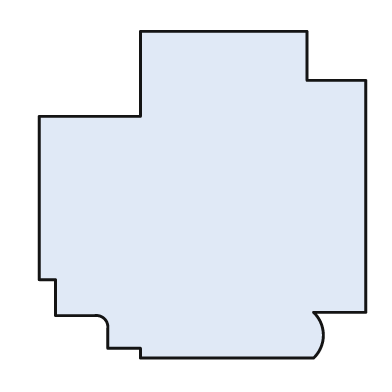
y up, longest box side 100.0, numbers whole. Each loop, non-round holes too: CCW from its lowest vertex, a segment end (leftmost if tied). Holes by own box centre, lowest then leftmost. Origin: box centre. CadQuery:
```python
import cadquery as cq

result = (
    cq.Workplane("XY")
    .moveTo(-19.0, -50.0)
    .lineTo(34.0, -50.0)
    .threePointArc((37.0, -43.0), (34.0, -36.0))
    .lineTo(50.0, -36.0)
    .lineTo(50.0, 35.0)
    .lineTo(32.0, 35.0)
    .lineTo(32.0, 50.0)
    .lineTo(-19.0, 50.0)
    .lineTo(-19.0, 24.0)
    .lineTo(-50.0, 24.0)
    .lineTo(-50.0, -26.0)
    .lineTo(-45.0, -26.0)
    .lineTo(-45.0, -37.0)
    .lineTo(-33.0, -37.0)
    .threePointArc((-30.0, -38.0), (-29.0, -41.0))
    .lineTo(-29.0, -47.0)
    .lineTo(-19.0, -47.0)
    .close()
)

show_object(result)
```